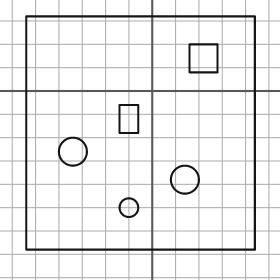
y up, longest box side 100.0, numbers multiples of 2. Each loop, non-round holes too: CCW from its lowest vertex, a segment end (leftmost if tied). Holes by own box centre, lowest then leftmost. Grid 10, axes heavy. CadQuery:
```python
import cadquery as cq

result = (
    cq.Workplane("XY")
    .moveTo(-54.0, -68.0)
    .lineTo(44.0, -68.0)
    .lineTo(44.0, 32.0)
    .lineTo(-54.0, 32.0)
    .close()
    .moveTo(-10.0, -50.0)
    .circle(4.0)
    .moveTo(14.0, -38.0)
    .circle(6.0)
    .moveTo(-34.0, -26.0)
    .circle(6.0)
    .moveTo(-14.0, -18.0)
    .lineTo(-6.0, -18.0)
    .lineTo(-6.0, -6.0)
    .lineTo(-14.0, -6.0)
    .close()
    .moveTo(16.0, 8.0)
    .lineTo(28.0, 8.0)
    .lineTo(28.0, 20.0)
    .lineTo(16.0, 20.0)
    .close()
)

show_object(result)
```